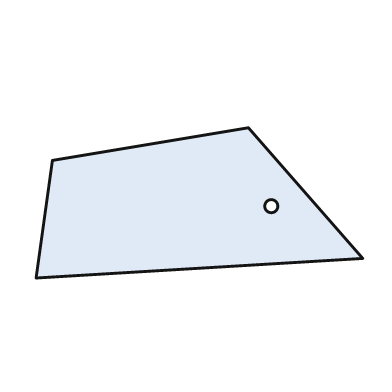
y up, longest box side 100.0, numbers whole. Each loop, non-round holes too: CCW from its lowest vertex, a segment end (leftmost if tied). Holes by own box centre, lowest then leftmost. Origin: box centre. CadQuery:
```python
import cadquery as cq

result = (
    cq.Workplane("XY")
    .moveTo(-50.0, -23.0)
    .lineTo(50.0, -17.0)
    .lineTo(15.0, 23.0)
    .lineTo(-45.0, 13.0)
    .close()
    .moveTo(22.0, -1.0)
    .circle(2.0)
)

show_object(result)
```